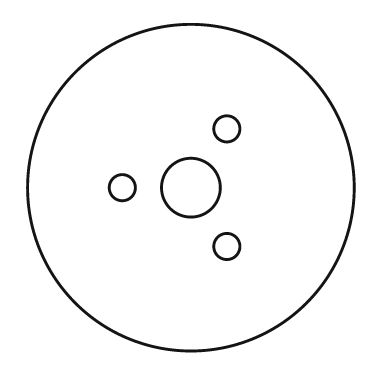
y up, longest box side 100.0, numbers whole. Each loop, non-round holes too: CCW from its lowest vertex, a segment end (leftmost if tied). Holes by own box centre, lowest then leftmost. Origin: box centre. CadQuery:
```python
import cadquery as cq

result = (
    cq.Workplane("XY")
    .moveTo(0.0, 0.0)
    .circle(50.0)
    .moveTo(11.0, -18.0)
    .circle(4.0)
    .moveTo(-21.0, 0.0)
    .circle(4.0)
    .moveTo(0.0, 0.0)
    .circle(9.0)
    .moveTo(11.0, 18.0)
    .circle(4.0)
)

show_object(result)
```